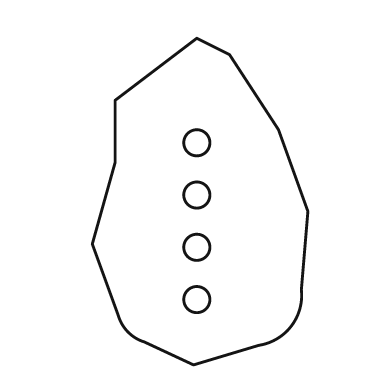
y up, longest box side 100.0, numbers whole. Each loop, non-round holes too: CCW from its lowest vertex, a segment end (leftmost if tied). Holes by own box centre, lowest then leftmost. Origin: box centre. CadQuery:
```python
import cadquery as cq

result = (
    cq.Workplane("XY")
    .moveTo(-2.0, -50.0)
    .lineTo(18.0, -44.0)
    .threePointArc((28.0, -38.0), (31.0, -27.0))
    .lineTo(33.0, -3.0)
    .lineTo(24.0, 22.0)
    .lineTo(9.0, 45.0)
    .lineTo(-1.0, 50.0)
    .lineTo(-26.0, 31.0)
    .lineTo(-26.0, 12.0)
    .lineTo(-33.0, -13.0)
    .lineTo(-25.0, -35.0)
    .threePointArc((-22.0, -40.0), (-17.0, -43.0))
    .close()
    .moveTo(-1.0, -30.0)
    .circle(4.0)
    .moveTo(-1.0, -14.0)
    .circle(4.0)
    .moveTo(-1.0, 2.0)
    .circle(4.0)
    .moveTo(-1.0, 18.0)
    .circle(4.0)
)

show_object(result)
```